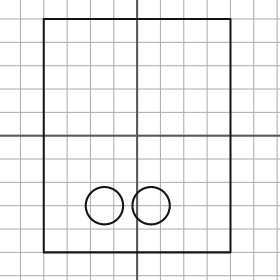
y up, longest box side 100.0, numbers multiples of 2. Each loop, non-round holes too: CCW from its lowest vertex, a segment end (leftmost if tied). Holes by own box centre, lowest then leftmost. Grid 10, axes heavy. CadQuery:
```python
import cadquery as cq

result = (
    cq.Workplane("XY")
    .moveTo(-40.0, -50.0)
    .lineTo(40.0, -50.0)
    .lineTo(40.0, 50.0)
    .lineTo(-40.0, 50.0)
    .close()
    .moveTo(-14.0, -30.0)
    .circle(8.0)
    .moveTo(6.0, -30.0)
    .circle(8.0)
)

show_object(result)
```